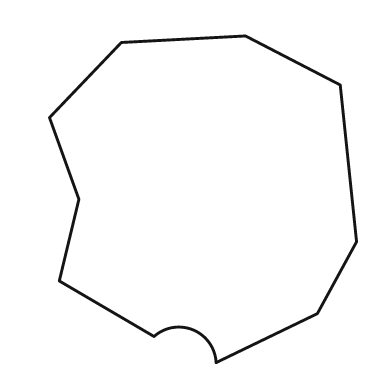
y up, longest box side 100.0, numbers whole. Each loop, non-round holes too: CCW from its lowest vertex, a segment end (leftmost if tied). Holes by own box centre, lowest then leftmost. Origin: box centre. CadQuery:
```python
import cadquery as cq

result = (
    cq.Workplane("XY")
    .moveTo(4.0, -50.0)
    .lineTo(35.0, -35.0)
    .lineTo(47.0, -13.0)
    .lineTo(42.0, 35.0)
    .lineTo(13.0, 50.0)
    .lineTo(-25.0, 48.0)
    .lineTo(-47.0, 25.0)
    .lineTo(-38.0, 0.0)
    .lineTo(-44.0, -25.0)
    .lineTo(-15.0, -42.0)
    .threePointArc((-3.0, -40.0), (4.0, -50.0))
    .close()
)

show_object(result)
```